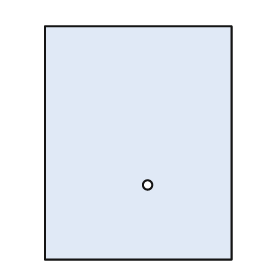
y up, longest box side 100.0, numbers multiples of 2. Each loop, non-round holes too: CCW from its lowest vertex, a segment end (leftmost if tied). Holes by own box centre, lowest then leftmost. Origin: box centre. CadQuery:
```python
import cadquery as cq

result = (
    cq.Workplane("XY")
    .moveTo(-40.0, -50.0)
    .lineTo(40.0, -50.0)
    .lineTo(40.0, 50.0)
    .lineTo(-40.0, 50.0)
    .close()
    .moveTo(4.0, -18.0)
    .circle(2.0)
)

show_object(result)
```